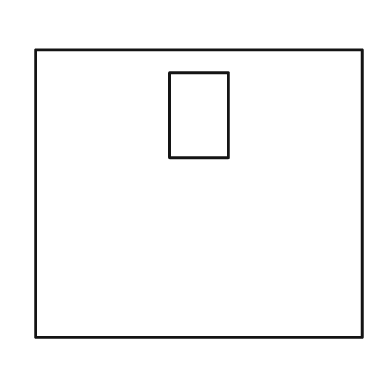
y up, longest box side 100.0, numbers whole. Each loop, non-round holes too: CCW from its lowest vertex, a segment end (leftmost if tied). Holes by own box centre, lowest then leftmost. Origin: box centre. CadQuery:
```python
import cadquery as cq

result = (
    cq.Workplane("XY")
    .moveTo(-50.0, -44.0)
    .lineTo(50.0, -44.0)
    .lineTo(50.0, 44.0)
    .lineTo(-50.0, 44.0)
    .close()
    .moveTo(-9.0, 11.0)
    .lineTo(9.0, 11.0)
    .lineTo(9.0, 37.0)
    .lineTo(-9.0, 37.0)
    .close()
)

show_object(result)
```